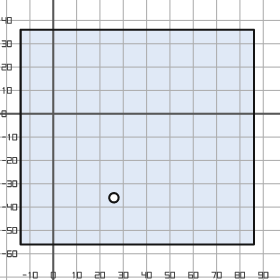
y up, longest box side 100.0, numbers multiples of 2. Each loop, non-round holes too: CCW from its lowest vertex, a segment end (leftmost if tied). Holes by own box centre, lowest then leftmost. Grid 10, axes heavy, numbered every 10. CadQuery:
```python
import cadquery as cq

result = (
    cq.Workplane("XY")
    .moveTo(-14.0, -56.0)
    .lineTo(86.0, -56.0)
    .lineTo(86.0, 36.0)
    .lineTo(-14.0, 36.0)
    .close()
    .moveTo(26.0, -36.0)
    .circle(2.0)
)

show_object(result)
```